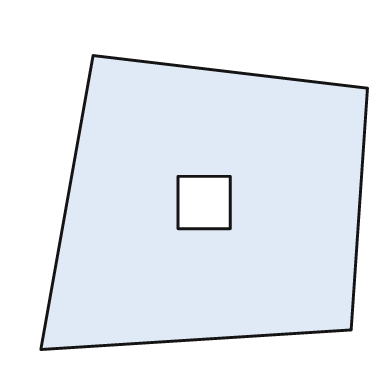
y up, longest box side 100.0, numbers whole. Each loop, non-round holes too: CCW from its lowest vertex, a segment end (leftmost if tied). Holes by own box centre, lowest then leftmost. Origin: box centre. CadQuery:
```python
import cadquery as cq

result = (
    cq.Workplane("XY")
    .moveTo(-50.0, -45.0)
    .lineTo(45.0, -39.0)
    .lineTo(50.0, 35.0)
    .lineTo(-34.0, 45.0)
    .close()
    .moveTo(-8.0, -8.0)
    .lineTo(8.0, -8.0)
    .lineTo(8.0, 8.0)
    .lineTo(-8.0, 8.0)
    .close()
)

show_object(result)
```